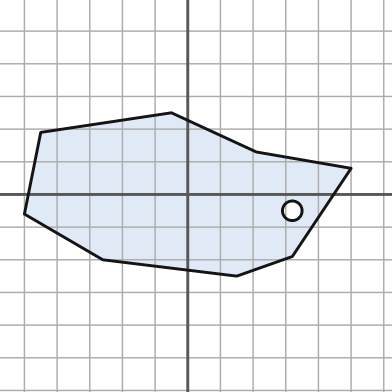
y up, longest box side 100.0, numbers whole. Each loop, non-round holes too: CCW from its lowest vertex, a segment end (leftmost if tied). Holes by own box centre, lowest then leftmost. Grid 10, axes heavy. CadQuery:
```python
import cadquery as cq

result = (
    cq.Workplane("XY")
    .moveTo(15.0, -25.0)
    .lineTo(32.0, -19.0)
    .lineTo(50.0, 8.0)
    .lineTo(21.0, 13.0)
    .lineTo(-5.0, 25.0)
    .lineTo(-45.0, 19.0)
    .lineTo(-50.0, -6.0)
    .lineTo(-26.0, -20.0)
    .close()
    .moveTo(32.0, -5.0)
    .circle(3.0)
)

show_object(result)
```